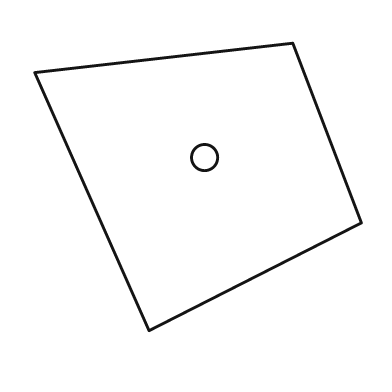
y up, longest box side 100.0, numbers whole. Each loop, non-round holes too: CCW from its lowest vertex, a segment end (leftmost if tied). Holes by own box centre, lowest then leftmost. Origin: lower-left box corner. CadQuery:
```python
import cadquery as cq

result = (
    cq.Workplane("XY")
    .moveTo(35.0, 0.0)
    .lineTo(100.0, 33.0)
    .lineTo(79.0, 88.0)
    .lineTo(0.0, 79.0)
    .close()
    .moveTo(52.0, 53.0)
    .circle(4.0)
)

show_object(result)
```